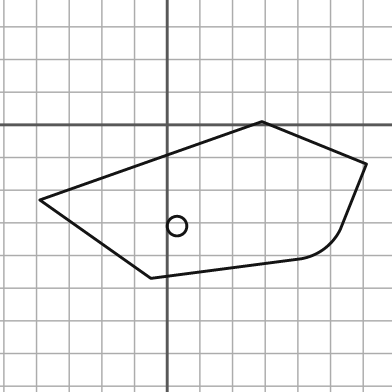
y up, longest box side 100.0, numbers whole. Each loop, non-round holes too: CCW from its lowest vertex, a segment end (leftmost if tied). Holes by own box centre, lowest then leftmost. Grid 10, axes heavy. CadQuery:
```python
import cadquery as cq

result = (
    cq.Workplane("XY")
    .moveTo(-5.0, -47.0)
    .lineTo(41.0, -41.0)
    .threePointArc((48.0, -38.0), (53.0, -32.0))
    .lineTo(61.0, -12.0)
    .lineTo(29.0, 1.0)
    .lineTo(-39.0, -23.0)
    .close()
    .moveTo(3.0, -31.0)
    .circle(3.0)
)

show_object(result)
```